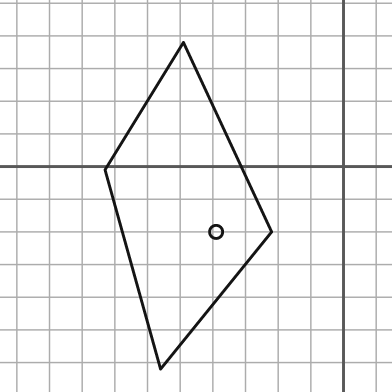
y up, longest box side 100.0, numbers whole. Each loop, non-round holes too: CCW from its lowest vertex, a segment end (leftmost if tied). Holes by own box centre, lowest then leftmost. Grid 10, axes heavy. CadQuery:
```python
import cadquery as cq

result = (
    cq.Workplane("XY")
    .moveTo(-56.0, -62.0)
    .lineTo(-22.0, -20.0)
    .lineTo(-49.0, 38.0)
    .lineTo(-73.0, -1.0)
    .close()
    .moveTo(-39.0, -20.0)
    .circle(2.0)
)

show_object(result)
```